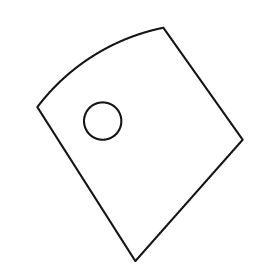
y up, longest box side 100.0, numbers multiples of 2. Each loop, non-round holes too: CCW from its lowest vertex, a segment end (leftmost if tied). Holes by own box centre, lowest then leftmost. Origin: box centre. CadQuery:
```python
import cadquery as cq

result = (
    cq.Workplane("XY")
    .moveTo(-2.0, -50.0)
    .lineTo(44.0, 2.0)
    .lineTo(10.0, 50.0)
    .threePointArc((-20.0, 38.0), (-44.0, 16.0))
    .close()
    .moveTo(-16.0, 10.0)
    .circle(8.0)
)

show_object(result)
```